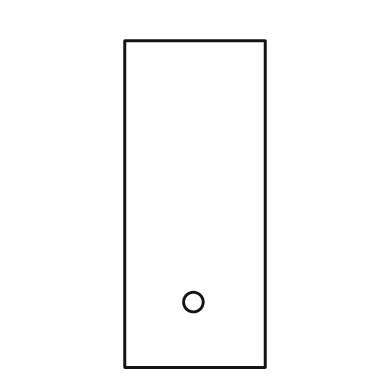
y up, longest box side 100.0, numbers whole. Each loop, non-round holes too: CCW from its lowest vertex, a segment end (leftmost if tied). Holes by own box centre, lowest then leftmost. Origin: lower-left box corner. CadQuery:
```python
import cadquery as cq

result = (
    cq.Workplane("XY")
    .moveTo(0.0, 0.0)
    .lineTo(43.0, 0.0)
    .lineTo(43.0, 100.0)
    .lineTo(0.0, 100.0)
    .close()
    .moveTo(21.0, 20.0)
    .circle(3.0)
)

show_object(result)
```